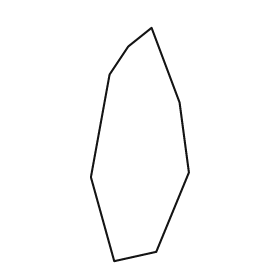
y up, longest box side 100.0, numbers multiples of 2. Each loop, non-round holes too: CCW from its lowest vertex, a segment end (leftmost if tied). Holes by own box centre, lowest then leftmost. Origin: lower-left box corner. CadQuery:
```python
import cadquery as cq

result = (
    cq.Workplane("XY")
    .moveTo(10.0, 0.0)
    .lineTo(28.0, 4.0)
    .lineTo(42.0, 38.0)
    .lineTo(38.0, 68.0)
    .lineTo(26.0, 100.0)
    .lineTo(16.0, 92.0)
    .lineTo(8.0, 80.0)
    .lineTo(0.0, 36.0)
    .close()
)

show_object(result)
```